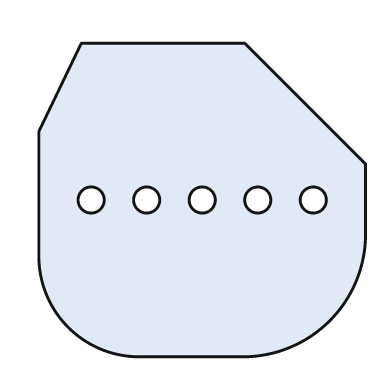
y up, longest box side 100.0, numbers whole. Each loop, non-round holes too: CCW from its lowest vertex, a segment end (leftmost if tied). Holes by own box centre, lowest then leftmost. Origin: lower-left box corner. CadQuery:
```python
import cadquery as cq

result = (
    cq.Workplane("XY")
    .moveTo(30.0, 0.0)
    .lineTo(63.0, 0.0)
    .threePointArc((89.0, 11.0), (100.0, 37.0))
    .lineTo(100.0, 59.0)
    .lineTo(63.0, 96.0)
    .lineTo(13.0, 96.0)
    .lineTo(0.0, 69.0)
    .lineTo(0.0, 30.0)
    .threePointArc((9.0, 9.0), (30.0, 0.0))
    .close()
    .moveTo(16.0, 48.0)
    .circle(4.0)
    .moveTo(33.0, 48.0)
    .circle(4.0)
    .moveTo(50.0, 48.0)
    .circle(4.0)
    .moveTo(67.0, 48.0)
    .circle(4.0)
    .moveTo(84.0, 48.0)
    .circle(4.0)
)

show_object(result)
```